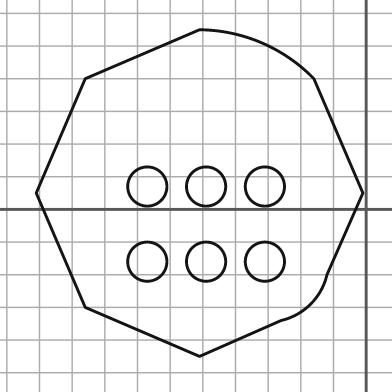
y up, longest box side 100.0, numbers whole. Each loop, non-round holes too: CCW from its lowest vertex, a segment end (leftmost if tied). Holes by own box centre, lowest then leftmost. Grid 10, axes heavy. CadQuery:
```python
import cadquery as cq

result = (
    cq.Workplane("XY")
    .moveTo(-51.0, -45.0)
    .lineTo(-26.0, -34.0)
    .threePointArc((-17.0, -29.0), (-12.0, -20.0))
    .lineTo(-1.0, 5.0)
    .lineTo(-16.0, 40.0)
    .threePointArc((-32.0, 51.0), (-51.0, 55.0))
    .lineTo(-86.0, 40.0)
    .lineTo(-101.0, 5.0)
    .lineTo(-86.0, -30.0)
    .close()
    .moveTo(-67.0, -16.0)
    .circle(6.0)
    .moveTo(-49.0, -16.0)
    .circle(6.0)
    .moveTo(-31.0, -16.0)
    .circle(6.0)
    .moveTo(-67.0, 7.0)
    .circle(6.0)
    .moveTo(-49.0, 7.0)
    .circle(6.0)
    .moveTo(-31.0, 7.0)
    .circle(6.0)
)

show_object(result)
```